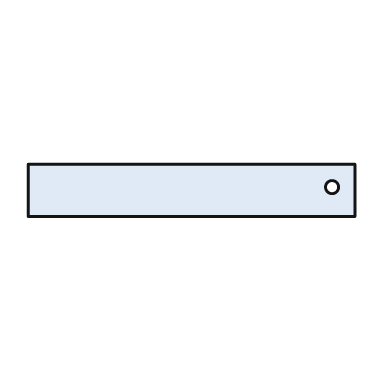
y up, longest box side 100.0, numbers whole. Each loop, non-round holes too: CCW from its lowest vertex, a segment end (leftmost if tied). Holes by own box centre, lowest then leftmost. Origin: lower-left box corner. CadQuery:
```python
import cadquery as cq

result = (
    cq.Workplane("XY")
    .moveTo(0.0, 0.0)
    .lineTo(100.0, 0.0)
    .lineTo(100.0, 16.0)
    .lineTo(0.0, 16.0)
    .close()
    .moveTo(93.0, 9.0)
    .circle(2.0)
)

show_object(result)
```